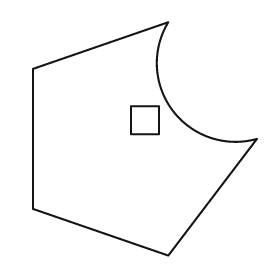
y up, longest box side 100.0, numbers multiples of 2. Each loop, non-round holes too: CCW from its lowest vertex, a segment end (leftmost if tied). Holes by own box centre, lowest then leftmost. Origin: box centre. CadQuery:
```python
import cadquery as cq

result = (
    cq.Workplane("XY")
    .moveTo(10.0, -50.0)
    .lineTo(48.0, 0.0)
    .threePointArc((12.0, 12.0), (10.0, 50.0))
    .lineTo(-48.0, 30.0)
    .lineTo(-48.0, -30.0)
    .close()
    .moveTo(-6.0, 2.0)
    .lineTo(6.0, 2.0)
    .lineTo(6.0, 14.0)
    .lineTo(-6.0, 14.0)
    .close()
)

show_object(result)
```